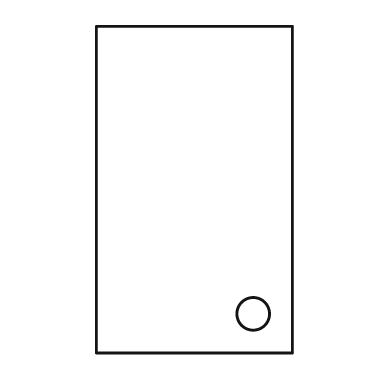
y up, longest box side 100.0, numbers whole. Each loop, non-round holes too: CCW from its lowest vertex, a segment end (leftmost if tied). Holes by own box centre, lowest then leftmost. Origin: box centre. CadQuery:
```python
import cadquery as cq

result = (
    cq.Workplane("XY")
    .moveTo(-30.0, -50.0)
    .lineTo(30.0, -50.0)
    .lineTo(30.0, 50.0)
    .lineTo(-30.0, 50.0)
    .close()
    .moveTo(18.0, -38.0)
    .circle(5.0)
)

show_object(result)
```